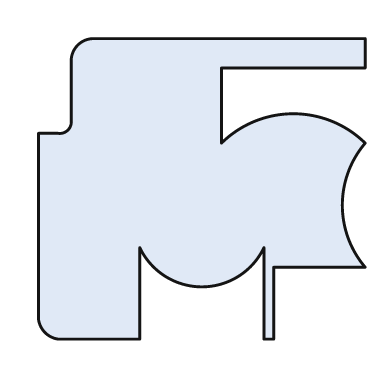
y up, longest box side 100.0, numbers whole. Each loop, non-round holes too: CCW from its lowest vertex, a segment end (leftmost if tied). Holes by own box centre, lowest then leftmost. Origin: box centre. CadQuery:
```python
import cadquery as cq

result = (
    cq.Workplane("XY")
    .moveTo(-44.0, -46.0)
    .lineTo(-19.0, -46.0)
    .lineTo(-19.0, -18.0)
    .threePointArc((0.0, -30.0), (19.0, -18.0))
    .lineTo(19.0, -46.0)
    .lineTo(22.0, -46.0)
    .lineTo(22.0, -24.0)
    .lineTo(50.0, -24.0)
    .threePointArc((43.0, -5.0), (50.0, 14.0))
    .threePointArc((28.0, 23.0), (6.0, 14.0))
    .lineTo(6.0, 37.0)
    .lineTo(50.0, 37.0)
    .lineTo(50.0, 46.0)
    .lineTo(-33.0, 46.0)
    .threePointArc((-38.0, 44.0), (-40.0, 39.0))
    .lineTo(-40.0, 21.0)
    .threePointArc((-41.0, 18.0), (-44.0, 17.0))
    .lineTo(-50.0, 17.0)
    .lineTo(-50.0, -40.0)
    .threePointArc((-48.0, -44.0), (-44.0, -46.0))
    .close()
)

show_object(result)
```